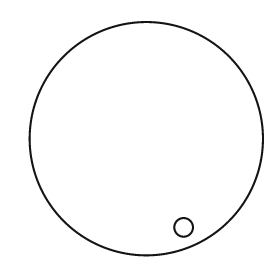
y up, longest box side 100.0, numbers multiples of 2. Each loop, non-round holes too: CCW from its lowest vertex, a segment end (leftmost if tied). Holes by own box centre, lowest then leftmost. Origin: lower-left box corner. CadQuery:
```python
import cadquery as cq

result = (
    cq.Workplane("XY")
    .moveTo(50.0, 50.0)
    .circle(50.0)
    .moveTo(66.0, 12.0)
    .circle(4.0)
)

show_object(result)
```